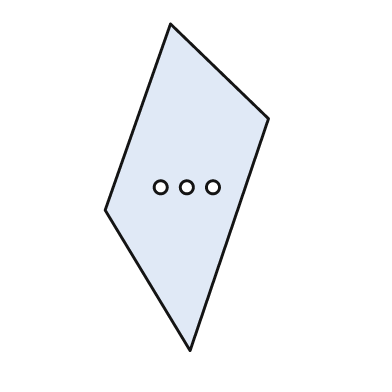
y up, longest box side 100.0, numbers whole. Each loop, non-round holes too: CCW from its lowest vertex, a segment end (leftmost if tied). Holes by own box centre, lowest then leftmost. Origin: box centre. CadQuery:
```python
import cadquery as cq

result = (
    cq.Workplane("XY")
    .moveTo(1.0, -50.0)
    .lineTo(25.0, 21.0)
    .lineTo(-5.0, 50.0)
    .lineTo(-25.0, -7.0)
    .close()
    .moveTo(-8.0, 0.0)
    .circle(2.0)
    .moveTo(0.0, 0.0)
    .circle(2.0)
    .moveTo(8.0, 0.0)
    .circle(2.0)
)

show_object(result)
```